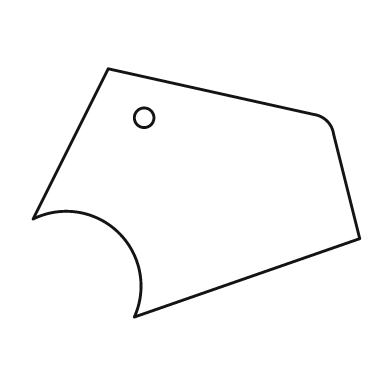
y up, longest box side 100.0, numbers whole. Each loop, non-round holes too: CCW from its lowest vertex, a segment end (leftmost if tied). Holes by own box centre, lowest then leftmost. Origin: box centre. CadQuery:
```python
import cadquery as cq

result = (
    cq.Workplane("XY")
    .moveTo(-19.0, -38.0)
    .lineTo(50.0, -14.0)
    .lineTo(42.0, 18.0)
    .threePointArc((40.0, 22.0), (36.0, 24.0))
    .lineTo(-27.0, 38.0)
    .lineTo(-50.0, -8.0)
    .threePointArc((-24.0, -12.0), (-19.0, -38.0))
    .close()
    .moveTo(-16.0, 23.0)
    .circle(3.0)
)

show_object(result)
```